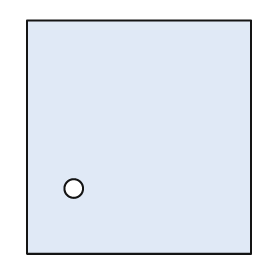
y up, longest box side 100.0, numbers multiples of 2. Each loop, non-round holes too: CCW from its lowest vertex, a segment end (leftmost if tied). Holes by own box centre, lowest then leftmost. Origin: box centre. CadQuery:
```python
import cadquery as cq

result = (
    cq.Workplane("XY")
    .moveTo(-48.0, -50.0)
    .lineTo(48.0, -50.0)
    .lineTo(48.0, 50.0)
    .lineTo(-48.0, 50.0)
    .close()
    .moveTo(-28.0, -22.0)
    .circle(4.0)
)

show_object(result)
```